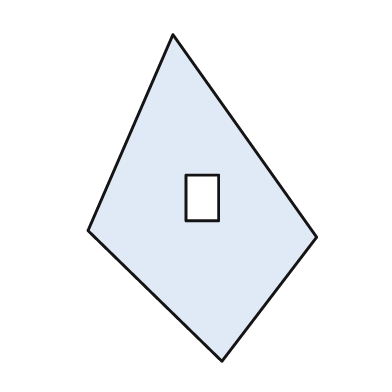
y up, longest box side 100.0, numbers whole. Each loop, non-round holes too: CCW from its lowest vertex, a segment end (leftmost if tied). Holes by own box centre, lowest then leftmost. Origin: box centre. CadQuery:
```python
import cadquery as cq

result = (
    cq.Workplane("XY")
    .moveTo(6.0, -50.0)
    .lineTo(35.0, -12.0)
    .lineTo(-9.0, 50.0)
    .lineTo(-35.0, -10.0)
    .close()
    .moveTo(-5.0, -7.0)
    .lineTo(5.0, -7.0)
    .lineTo(5.0, 7.0)
    .lineTo(-5.0, 7.0)
    .close()
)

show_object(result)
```